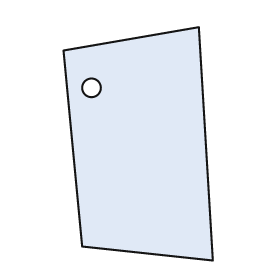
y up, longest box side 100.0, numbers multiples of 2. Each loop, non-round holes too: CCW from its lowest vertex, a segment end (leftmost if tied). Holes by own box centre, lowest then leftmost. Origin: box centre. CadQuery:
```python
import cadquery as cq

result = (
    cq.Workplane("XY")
    .moveTo(32.0, -50.0)
    .lineTo(26.0, 50.0)
    .lineTo(-32.0, 40.0)
    .lineTo(-24.0, -44.0)
    .close()
    .moveTo(-20.0, 24.0)
    .circle(4.0)
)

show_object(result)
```